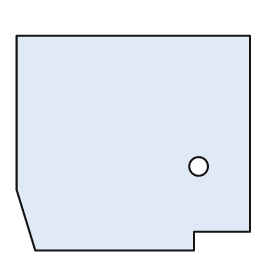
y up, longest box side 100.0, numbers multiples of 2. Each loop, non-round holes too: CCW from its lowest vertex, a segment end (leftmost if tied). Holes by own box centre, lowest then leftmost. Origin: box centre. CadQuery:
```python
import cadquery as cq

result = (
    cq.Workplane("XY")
    .moveTo(-42.0, -46.0)
    .lineTo(26.0, -46.0)
    .lineTo(26.0, -38.0)
    .lineTo(50.0, -38.0)
    .lineTo(50.0, 46.0)
    .lineTo(-50.0, 46.0)
    .lineTo(-50.0, -20.0)
    .close()
    .moveTo(28.0, -10.0)
    .circle(4.0)
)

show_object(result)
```